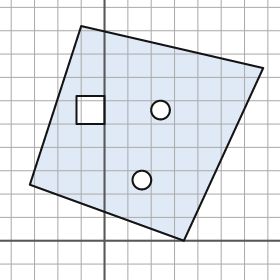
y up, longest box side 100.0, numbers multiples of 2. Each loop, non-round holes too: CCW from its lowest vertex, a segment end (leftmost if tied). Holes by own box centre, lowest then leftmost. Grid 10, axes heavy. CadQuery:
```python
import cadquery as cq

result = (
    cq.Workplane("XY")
    .moveTo(34.0, 0.0)
    .lineTo(68.0, 74.0)
    .lineTo(-10.0, 92.0)
    .lineTo(-32.0, 24.0)
    .close()
    .moveTo(16.0, 26.0)
    .circle(4.0)
    .moveTo(-12.0, 50.0)
    .lineTo(0.0, 50.0)
    .lineTo(0.0, 62.0)
    .lineTo(-12.0, 62.0)
    .close()
    .moveTo(24.0, 56.0)
    .circle(4.0)
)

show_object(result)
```